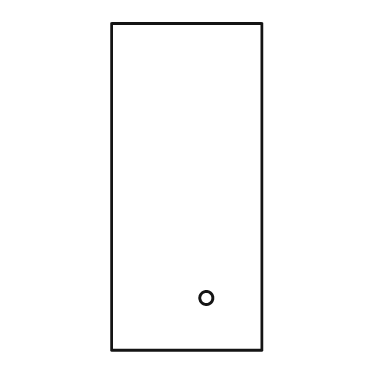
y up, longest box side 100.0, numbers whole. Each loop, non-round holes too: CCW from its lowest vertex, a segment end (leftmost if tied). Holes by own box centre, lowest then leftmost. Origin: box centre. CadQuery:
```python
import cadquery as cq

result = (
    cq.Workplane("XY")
    .moveTo(-23.0, -50.0)
    .lineTo(23.0, -50.0)
    .lineTo(23.0, 50.0)
    .lineTo(-23.0, 50.0)
    .close()
    .moveTo(6.0, -34.0)
    .circle(2.0)
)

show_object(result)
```